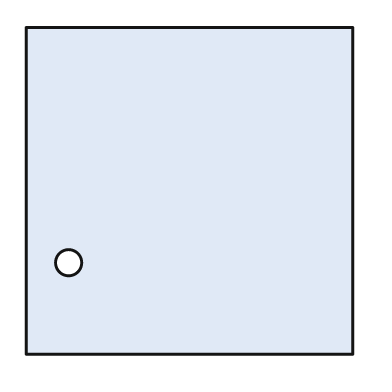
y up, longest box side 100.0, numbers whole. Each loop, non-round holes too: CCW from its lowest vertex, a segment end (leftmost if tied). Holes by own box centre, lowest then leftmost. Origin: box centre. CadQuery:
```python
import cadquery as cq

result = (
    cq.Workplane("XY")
    .moveTo(-50.0, -50.0)
    .lineTo(50.0, -50.0)
    .lineTo(50.0, 50.0)
    .lineTo(-50.0, 50.0)
    .close()
    .moveTo(-37.0, -22.0)
    .circle(4.0)
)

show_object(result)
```